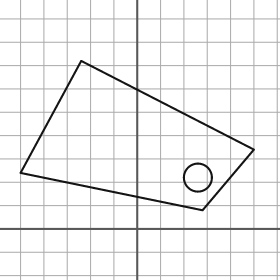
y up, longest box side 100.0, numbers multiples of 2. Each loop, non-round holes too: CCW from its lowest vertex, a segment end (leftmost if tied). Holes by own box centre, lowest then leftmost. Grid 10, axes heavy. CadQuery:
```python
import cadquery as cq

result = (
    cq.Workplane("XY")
    .moveTo(28.0, 8.0)
    .lineTo(50.0, 34.0)
    .lineTo(-24.0, 72.0)
    .lineTo(-50.0, 24.0)
    .close()
    .moveTo(26.0, 22.0)
    .circle(6.0)
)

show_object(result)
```